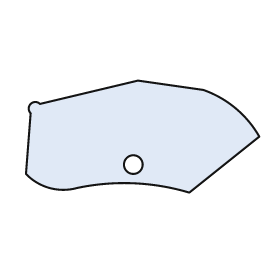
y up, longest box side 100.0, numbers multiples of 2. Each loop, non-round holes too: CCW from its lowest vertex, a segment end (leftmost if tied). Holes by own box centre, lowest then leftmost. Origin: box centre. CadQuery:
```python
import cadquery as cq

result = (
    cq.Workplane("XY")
    .moveTo(20.0, -24.0)
    .lineTo(50.0, 0.0)
    .threePointArc((40.0, 12.0), (26.0, 20.0))
    .lineTo(-2.0, 24.0)
    .lineTo(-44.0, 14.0)
    .threePointArc((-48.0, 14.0), (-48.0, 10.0))
    .lineTo(-50.0, -16.0)
    .threePointArc((-40.0, -22.0), (-28.0, -22.0))
    .threePointArc((-4.0, -20.0), (20.0, -24.0))
    .close()
    .moveTo(-4.0, -12.0)
    .circle(4.0)
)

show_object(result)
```